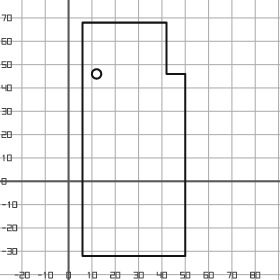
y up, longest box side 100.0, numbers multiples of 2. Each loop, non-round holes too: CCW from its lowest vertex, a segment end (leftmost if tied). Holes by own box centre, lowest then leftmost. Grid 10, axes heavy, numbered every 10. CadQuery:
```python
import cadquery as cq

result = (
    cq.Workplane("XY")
    .moveTo(6.0, -32.0)
    .lineTo(50.0, -32.0)
    .lineTo(50.0, 46.0)
    .lineTo(42.0, 46.0)
    .lineTo(42.0, 68.0)
    .lineTo(6.0, 68.0)
    .close()
    .moveTo(12.0, 46.0)
    .circle(2.0)
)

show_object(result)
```